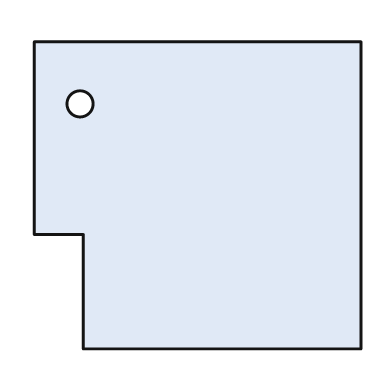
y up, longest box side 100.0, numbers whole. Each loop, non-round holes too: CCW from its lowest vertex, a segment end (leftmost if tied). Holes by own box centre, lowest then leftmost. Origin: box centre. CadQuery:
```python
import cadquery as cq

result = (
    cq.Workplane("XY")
    .moveTo(-35.0, -47.0)
    .lineTo(50.0, -47.0)
    .lineTo(50.0, 47.0)
    .lineTo(-50.0, 47.0)
    .lineTo(-50.0, -12.0)
    .lineTo(-35.0, -12.0)
    .close()
    .moveTo(-36.0, 28.0)
    .circle(4.0)
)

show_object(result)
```